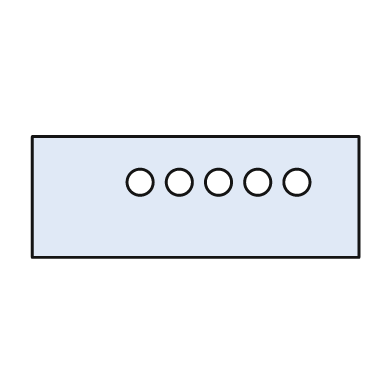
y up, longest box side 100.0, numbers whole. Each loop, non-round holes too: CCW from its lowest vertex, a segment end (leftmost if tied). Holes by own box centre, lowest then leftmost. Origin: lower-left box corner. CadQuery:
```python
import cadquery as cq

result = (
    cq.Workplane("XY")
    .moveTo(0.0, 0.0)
    .lineTo(100.0, 0.0)
    .lineTo(100.0, 37.0)
    .lineTo(0.0, 37.0)
    .close()
    .moveTo(33.0, 23.0)
    .circle(4.0)
    .moveTo(45.0, 23.0)
    .circle(4.0)
    .moveTo(57.0, 23.0)
    .circle(4.0)
    .moveTo(69.0, 23.0)
    .circle(4.0)
    .moveTo(81.0, 23.0)
    .circle(4.0)
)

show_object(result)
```